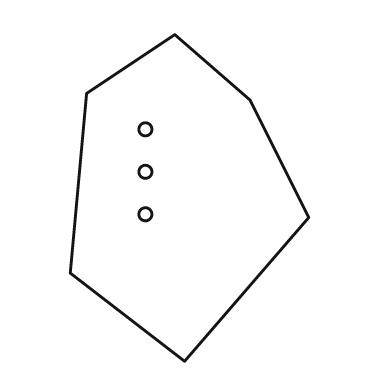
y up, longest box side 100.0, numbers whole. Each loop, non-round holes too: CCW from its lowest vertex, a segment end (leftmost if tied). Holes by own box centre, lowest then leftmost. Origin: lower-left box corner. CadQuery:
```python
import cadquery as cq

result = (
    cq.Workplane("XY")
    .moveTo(35.0, 0.0)
    .lineTo(73.0, 44.0)
    .lineTo(55.0, 80.0)
    .lineTo(32.0, 100.0)
    .lineTo(5.0, 82.0)
    .lineTo(0.0, 27.0)
    .close()
    .moveTo(23.0, 45.0)
    .circle(2.0)
    .moveTo(23.0, 58.0)
    .circle(2.0)
    .moveTo(23.0, 71.0)
    .circle(2.0)
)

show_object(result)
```